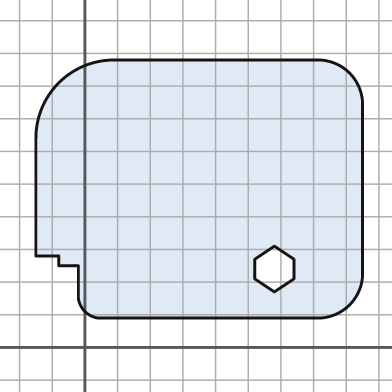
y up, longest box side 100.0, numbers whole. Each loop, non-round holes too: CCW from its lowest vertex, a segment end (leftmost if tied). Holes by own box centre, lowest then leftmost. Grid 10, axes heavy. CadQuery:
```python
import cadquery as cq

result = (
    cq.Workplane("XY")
    .moveTo(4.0, 9.0)
    .lineTo(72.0, 9.0)
    .threePointArc((81.0, 13.0), (85.0, 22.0))
    .lineTo(85.0, 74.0)
    .threePointArc((81.0, 84.0), (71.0, 88.0))
    .lineTo(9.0, 88.0)
    .threePointArc((-8.0, 81.0), (-15.0, 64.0))
    .lineTo(-15.0, 28.0)
    .lineTo(-8.0, 28.0)
    .lineTo(-8.0, 25.0)
    .lineTo(-2.0, 25.0)
    .lineTo(-2.0, 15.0)
    .threePointArc((0.0, 11.0), (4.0, 9.0))
    .close()
    .moveTo(58.0, 17.0)
    .lineTo(64.0, 21.0)
    .lineTo(64.0, 27.0)
    .lineTo(58.0, 31.0)
    .lineTo(52.0, 27.0)
    .lineTo(52.0, 21.0)
    .close()
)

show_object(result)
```